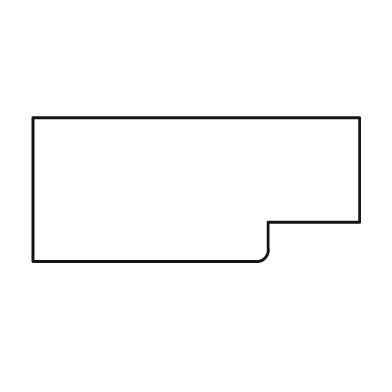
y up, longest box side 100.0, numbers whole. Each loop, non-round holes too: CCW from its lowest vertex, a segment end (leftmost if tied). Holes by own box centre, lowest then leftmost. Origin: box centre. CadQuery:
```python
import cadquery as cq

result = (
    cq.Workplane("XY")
    .moveTo(-50.0, -22.0)
    .lineTo(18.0, -22.0)
    .threePointArc((21.0, -21.0), (22.0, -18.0))
    .lineTo(22.0, -10.0)
    .lineTo(50.0, -10.0)
    .lineTo(50.0, 22.0)
    .lineTo(-50.0, 22.0)
    .close()
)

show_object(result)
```